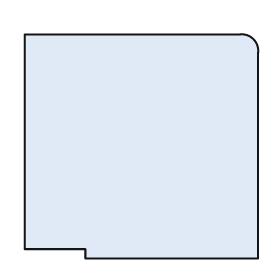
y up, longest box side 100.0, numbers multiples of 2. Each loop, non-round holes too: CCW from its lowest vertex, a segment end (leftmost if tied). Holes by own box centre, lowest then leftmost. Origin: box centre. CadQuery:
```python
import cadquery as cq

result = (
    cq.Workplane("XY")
    .moveTo(-24.0, -48.0)
    .lineTo(50.0, -48.0)
    .lineTo(50.0, 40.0)
    .threePointArc((48.0, 46.0), (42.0, 48.0))
    .lineTo(-50.0, 48.0)
    .lineTo(-50.0, -44.0)
    .lineTo(-24.0, -44.0)
    .close()
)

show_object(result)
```